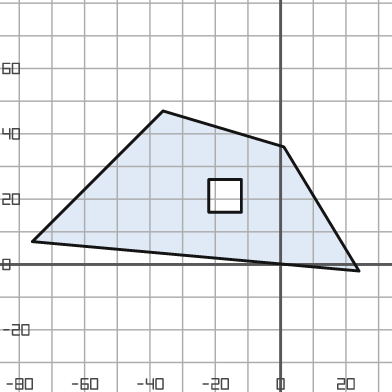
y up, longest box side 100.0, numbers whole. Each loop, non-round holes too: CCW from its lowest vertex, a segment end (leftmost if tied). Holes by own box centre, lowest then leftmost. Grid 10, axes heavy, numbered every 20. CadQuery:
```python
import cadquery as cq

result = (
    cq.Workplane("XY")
    .moveTo(24.0, -2.0)
    .lineTo(1.0, 36.0)
    .lineTo(-36.0, 47.0)
    .lineTo(-76.0, 7.0)
    .close()
    .moveTo(-22.0, 16.0)
    .lineTo(-12.0, 16.0)
    .lineTo(-12.0, 26.0)
    .lineTo(-22.0, 26.0)
    .close()
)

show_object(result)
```